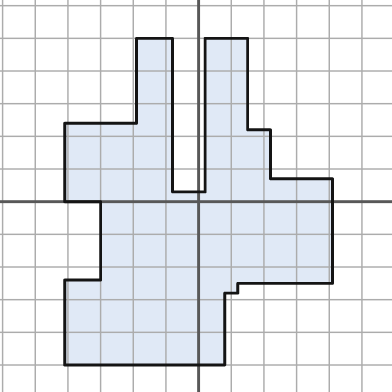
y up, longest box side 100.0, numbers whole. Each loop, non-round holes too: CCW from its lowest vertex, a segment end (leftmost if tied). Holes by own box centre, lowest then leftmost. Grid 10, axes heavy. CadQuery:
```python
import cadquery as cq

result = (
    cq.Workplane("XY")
    .moveTo(-41.0, -50.0)
    .lineTo(8.0, -50.0)
    .lineTo(8.0, -28.0)
    .lineTo(12.0, -28.0)
    .lineTo(12.0, -25.0)
    .lineTo(41.0, -25.0)
    .lineTo(41.0, 7.0)
    .lineTo(22.0, 7.0)
    .lineTo(22.0, 22.0)
    .lineTo(15.0, 22.0)
    .lineTo(15.0, 50.0)
    .lineTo(2.0, 50.0)
    .lineTo(2.0, 3.0)
    .lineTo(-8.0, 3.0)
    .lineTo(-8.0, 50.0)
    .lineTo(-19.0, 50.0)
    .lineTo(-19.0, 24.0)
    .lineTo(-41.0, 24.0)
    .lineTo(-41.0, 0.0)
    .lineTo(-30.0, 0.0)
    .lineTo(-30.0, -24.0)
    .lineTo(-41.0, -24.0)
    .close()
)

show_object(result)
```